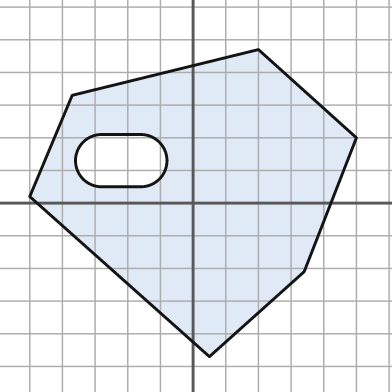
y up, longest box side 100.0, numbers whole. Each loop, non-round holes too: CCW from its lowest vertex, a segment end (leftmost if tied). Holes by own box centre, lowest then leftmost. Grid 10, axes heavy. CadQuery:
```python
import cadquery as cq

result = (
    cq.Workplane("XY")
    .moveTo(5.0, -47.0)
    .lineTo(34.0, -21.0)
    .lineTo(50.0, 20.0)
    .lineTo(20.0, 47.0)
    .lineTo(-37.0, 33.0)
    .lineTo(-50.0, 2.0)
    .close()
    .moveTo(-28.0, 5.0)
    .lineTo(-16.0, 5.0)
    .threePointArc((-8.0, 13.0), (-16.0, 21.0))
    .lineTo(-28.0, 21.0)
    .threePointArc((-36.0, 13.0), (-28.0, 5.0))
    .close()
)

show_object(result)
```